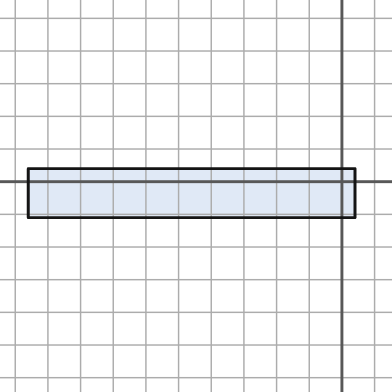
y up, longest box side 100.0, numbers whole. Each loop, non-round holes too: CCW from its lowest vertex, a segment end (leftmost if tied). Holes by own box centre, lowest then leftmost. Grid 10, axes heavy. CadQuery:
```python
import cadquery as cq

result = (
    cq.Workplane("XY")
    .moveTo(-96.0, -11.0)
    .lineTo(4.0, -11.0)
    .lineTo(4.0, 4.0)
    .lineTo(-96.0, 4.0)
    .close()
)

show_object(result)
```